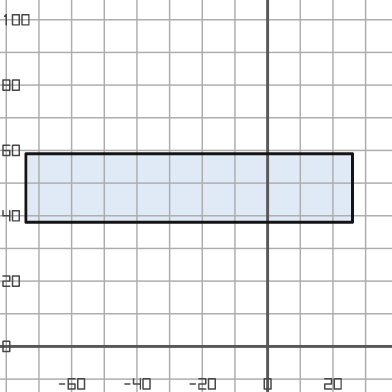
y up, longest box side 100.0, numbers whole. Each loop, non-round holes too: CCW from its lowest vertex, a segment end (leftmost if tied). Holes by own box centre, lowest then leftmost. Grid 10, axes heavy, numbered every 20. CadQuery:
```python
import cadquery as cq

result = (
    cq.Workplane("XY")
    .moveTo(-74.0, 38.0)
    .lineTo(26.0, 38.0)
    .lineTo(26.0, 59.0)
    .lineTo(-74.0, 59.0)
    .close()
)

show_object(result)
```